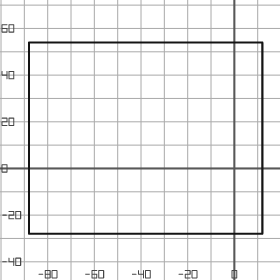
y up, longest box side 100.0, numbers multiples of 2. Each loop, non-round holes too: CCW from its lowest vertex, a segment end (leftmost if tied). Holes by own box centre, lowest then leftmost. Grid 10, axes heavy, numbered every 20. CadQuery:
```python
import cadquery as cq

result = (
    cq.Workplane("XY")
    .moveTo(-88.0, -28.0)
    .lineTo(12.0, -28.0)
    .lineTo(12.0, 54.0)
    .lineTo(-88.0, 54.0)
    .close()
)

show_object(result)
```